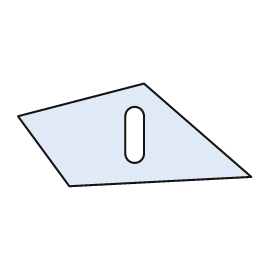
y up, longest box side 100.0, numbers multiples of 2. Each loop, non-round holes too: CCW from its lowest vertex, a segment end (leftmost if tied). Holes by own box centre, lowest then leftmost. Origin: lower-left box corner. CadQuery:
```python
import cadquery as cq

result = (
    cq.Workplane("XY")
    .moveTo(22.0, 0.0)
    .lineTo(100.0, 4.0)
    .lineTo(54.0, 44.0)
    .lineTo(0.0, 30.0)
    .close()
    .moveTo(46.0, 14.0)
    .threePointArc((50.0, 10.0), (54.0, 14.0))
    .lineTo(54.0, 30.0)
    .threePointArc((50.0, 34.0), (46.0, 30.0))
    .close()
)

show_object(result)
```